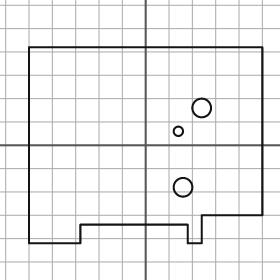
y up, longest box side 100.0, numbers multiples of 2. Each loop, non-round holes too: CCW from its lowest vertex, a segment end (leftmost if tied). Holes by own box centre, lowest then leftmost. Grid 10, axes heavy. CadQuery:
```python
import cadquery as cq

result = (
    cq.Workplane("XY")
    .moveTo(-50.0, -42.0)
    .lineTo(-28.0, -42.0)
    .lineTo(-28.0, -34.0)
    .lineTo(18.0, -34.0)
    .lineTo(18.0, -42.0)
    .lineTo(24.0, -42.0)
    .lineTo(24.0, -30.0)
    .lineTo(50.0, -30.0)
    .lineTo(50.0, 42.0)
    .lineTo(-50.0, 42.0)
    .close()
    .moveTo(16.0, -18.0)
    .circle(4.0)
    .moveTo(14.0, 6.0)
    .circle(2.0)
    .moveTo(24.0, 16.0)
    .circle(4.0)
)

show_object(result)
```